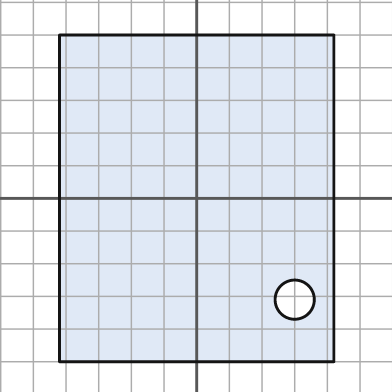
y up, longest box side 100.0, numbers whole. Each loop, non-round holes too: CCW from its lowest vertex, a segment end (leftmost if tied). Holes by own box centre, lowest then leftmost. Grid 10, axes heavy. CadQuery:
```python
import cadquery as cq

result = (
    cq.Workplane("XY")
    .moveTo(-42.0, -50.0)
    .lineTo(42.0, -50.0)
    .lineTo(42.0, 50.0)
    .lineTo(-42.0, 50.0)
    .close()
    .moveTo(30.0, -31.0)
    .circle(6.0)
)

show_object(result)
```